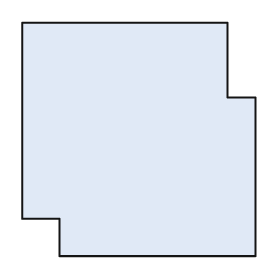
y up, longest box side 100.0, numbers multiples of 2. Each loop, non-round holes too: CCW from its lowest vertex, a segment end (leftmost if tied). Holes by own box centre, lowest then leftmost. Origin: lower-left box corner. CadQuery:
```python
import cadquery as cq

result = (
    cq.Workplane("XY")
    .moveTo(16.0, 0.0)
    .lineTo(100.0, 0.0)
    .lineTo(100.0, 68.0)
    .lineTo(88.0, 68.0)
    .lineTo(88.0, 100.0)
    .lineTo(0.0, 100.0)
    .lineTo(0.0, 16.0)
    .lineTo(16.0, 16.0)
    .close()
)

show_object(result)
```